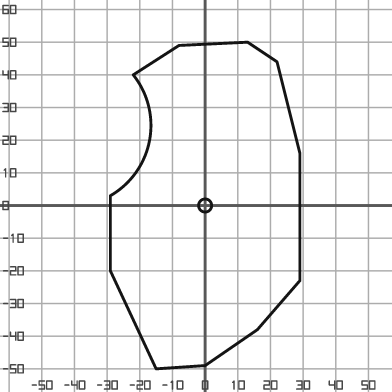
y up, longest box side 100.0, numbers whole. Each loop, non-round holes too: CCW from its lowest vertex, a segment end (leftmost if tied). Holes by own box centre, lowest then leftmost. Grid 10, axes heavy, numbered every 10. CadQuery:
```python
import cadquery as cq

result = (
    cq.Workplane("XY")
    .moveTo(-15.0, -50.0)
    .lineTo(0.0, -49.0)
    .lineTo(16.0, -38.0)
    .lineTo(29.0, -23.0)
    .lineTo(29.0, 16.0)
    .lineTo(22.0, 44.0)
    .lineTo(13.0, 50.0)
    .lineTo(-8.0, 49.0)
    .lineTo(-22.0, 40.0)
    .threePointArc((-17.0, 20.0), (-29.0, 3.0))
    .lineTo(-29.0, -20.0)
    .close()
    .moveTo(0.0, 0.0)
    .circle(2.0)
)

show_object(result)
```